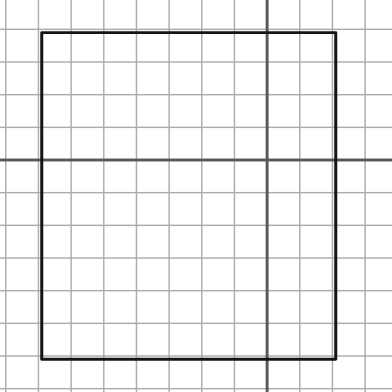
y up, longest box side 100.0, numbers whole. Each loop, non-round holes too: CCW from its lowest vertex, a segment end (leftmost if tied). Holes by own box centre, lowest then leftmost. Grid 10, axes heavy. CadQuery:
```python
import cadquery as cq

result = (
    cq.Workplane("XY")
    .moveTo(-69.0, -61.0)
    .lineTo(21.0, -61.0)
    .lineTo(21.0, 39.0)
    .lineTo(-69.0, 39.0)
    .close()
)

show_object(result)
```